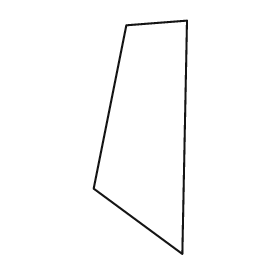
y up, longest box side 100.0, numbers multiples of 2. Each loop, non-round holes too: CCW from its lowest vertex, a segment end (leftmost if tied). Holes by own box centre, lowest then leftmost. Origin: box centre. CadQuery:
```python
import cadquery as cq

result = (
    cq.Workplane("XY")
    .moveTo(18.0, -50.0)
    .lineTo(20.0, 50.0)
    .lineTo(-6.0, 48.0)
    .lineTo(-20.0, -22.0)
    .close()
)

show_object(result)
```